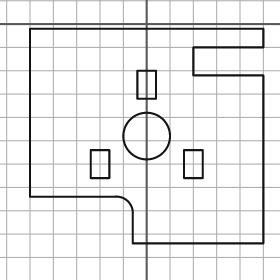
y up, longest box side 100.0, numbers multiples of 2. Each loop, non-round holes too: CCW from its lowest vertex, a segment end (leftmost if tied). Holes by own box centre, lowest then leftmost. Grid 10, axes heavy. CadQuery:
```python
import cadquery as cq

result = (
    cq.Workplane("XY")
    .moveTo(-6.0, -94.0)
    .lineTo(50.0, -94.0)
    .lineTo(50.0, -22.0)
    .lineTo(20.0, -22.0)
    .lineTo(20.0, -10.0)
    .lineTo(50.0, -10.0)
    .lineTo(50.0, -2.0)
    .lineTo(-50.0, -2.0)
    .lineTo(-50.0, -74.0)
    .lineTo(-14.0, -74.0)
    .threePointArc((-8.0, -76.0), (-6.0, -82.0))
    .close()
    .moveTo(-24.0, -66.0)
    .lineTo(-16.0, -66.0)
    .lineTo(-16.0, -54.0)
    .lineTo(-24.0, -54.0)
    .close()
    .moveTo(16.0, -66.0)
    .lineTo(24.0, -66.0)
    .lineTo(24.0, -54.0)
    .lineTo(16.0, -54.0)
    .close()
    .moveTo(0.0, -48.0)
    .circle(10.0)
    .moveTo(-4.0, -32.0)
    .lineTo(4.0, -32.0)
    .lineTo(4.0, -20.0)
    .lineTo(-4.0, -20.0)
    .close()
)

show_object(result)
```